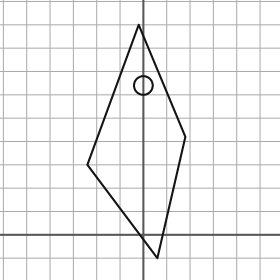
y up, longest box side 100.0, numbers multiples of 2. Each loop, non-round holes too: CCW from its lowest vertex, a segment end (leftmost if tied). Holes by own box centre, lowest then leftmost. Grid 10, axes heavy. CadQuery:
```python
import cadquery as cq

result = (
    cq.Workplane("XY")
    .moveTo(6.0, -10.0)
    .lineTo(18.0, 42.0)
    .lineTo(-2.0, 90.0)
    .lineTo(-24.0, 30.0)
    .close()
    .moveTo(0.0, 64.0)
    .circle(4.0)
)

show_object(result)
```